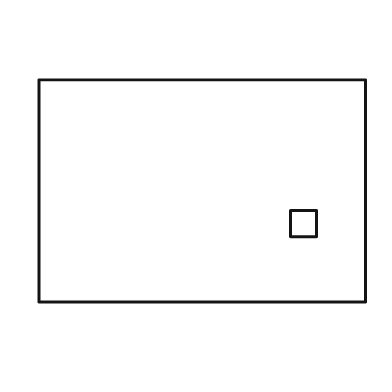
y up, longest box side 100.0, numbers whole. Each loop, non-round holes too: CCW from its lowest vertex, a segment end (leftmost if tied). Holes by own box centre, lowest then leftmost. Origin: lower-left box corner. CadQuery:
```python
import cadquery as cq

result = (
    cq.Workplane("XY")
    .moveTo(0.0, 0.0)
    .lineTo(100.0, 0.0)
    .lineTo(100.0, 68.0)
    .lineTo(0.0, 68.0)
    .close()
    .moveTo(77.0, 20.0)
    .lineTo(85.0, 20.0)
    .lineTo(85.0, 28.0)
    .lineTo(77.0, 28.0)
    .close()
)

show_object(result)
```